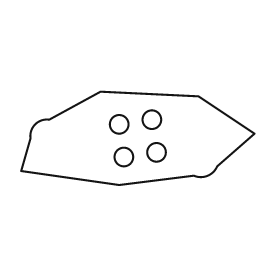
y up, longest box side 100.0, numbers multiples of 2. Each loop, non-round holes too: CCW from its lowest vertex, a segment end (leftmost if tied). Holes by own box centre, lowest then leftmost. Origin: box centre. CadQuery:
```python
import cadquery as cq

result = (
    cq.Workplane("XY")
    .moveTo(-8.0, -20.0)
    .lineTo(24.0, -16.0)
    .threePointArc((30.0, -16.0), (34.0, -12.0))
    .lineTo(50.0, 2.0)
    .lineTo(26.0, 18.0)
    .lineTo(-16.0, 20.0)
    .lineTo(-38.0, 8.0)
    .threePointArc((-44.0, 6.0), (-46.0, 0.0))
    .lineTo(-50.0, -14.0)
    .close()
    .moveTo(-6.0, -8.0)
    .circle(4.0)
    .moveTo(8.0, -6.0)
    .circle(4.0)
    .moveTo(-8.0, 6.0)
    .circle(4.0)
    .moveTo(6.0, 8.0)
    .circle(4.0)
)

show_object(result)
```